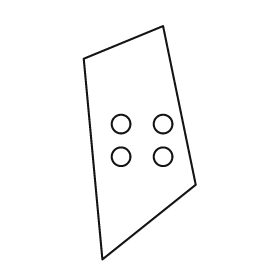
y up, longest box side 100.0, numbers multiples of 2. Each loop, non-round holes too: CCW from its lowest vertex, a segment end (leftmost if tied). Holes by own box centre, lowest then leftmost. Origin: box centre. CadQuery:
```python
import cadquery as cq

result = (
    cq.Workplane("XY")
    .moveTo(-16.0, -50.0)
    .lineTo(24.0, -18.0)
    .lineTo(10.0, 50.0)
    .lineTo(-24.0, 36.0)
    .close()
    .moveTo(-8.0, -6.0)
    .circle(4.0)
    .moveTo(10.0, -6.0)
    .circle(4.0)
    .moveTo(-8.0, 8.0)
    .circle(4.0)
    .moveTo(10.0, 8.0)
    .circle(4.0)
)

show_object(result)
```